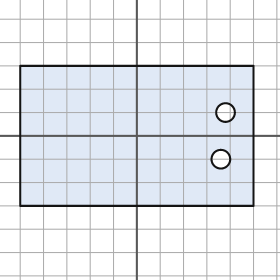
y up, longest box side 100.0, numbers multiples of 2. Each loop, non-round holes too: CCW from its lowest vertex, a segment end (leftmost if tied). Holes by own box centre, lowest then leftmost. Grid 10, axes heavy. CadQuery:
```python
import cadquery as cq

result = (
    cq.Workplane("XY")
    .moveTo(-50.0, -30.0)
    .lineTo(50.0, -30.0)
    .lineTo(50.0, 30.0)
    .lineTo(-50.0, 30.0)
    .close()
    .moveTo(36.0, -10.0)
    .circle(4.0)
    .moveTo(38.0, 10.0)
    .circle(4.0)
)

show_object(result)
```